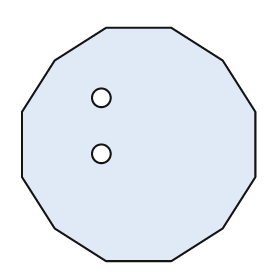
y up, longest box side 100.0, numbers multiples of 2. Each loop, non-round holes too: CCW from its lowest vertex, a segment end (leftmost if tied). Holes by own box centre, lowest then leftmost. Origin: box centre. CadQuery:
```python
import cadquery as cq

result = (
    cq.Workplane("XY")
    .moveTo(-14.0, -50.0)
    .lineTo(14.0, -50.0)
    .lineTo(36.0, -36.0)
    .lineTo(50.0, -14.0)
    .lineTo(50.0, 14.0)
    .lineTo(36.0, 36.0)
    .lineTo(14.0, 50.0)
    .lineTo(-14.0, 50.0)
    .lineTo(-36.0, 36.0)
    .lineTo(-50.0, 14.0)
    .lineTo(-50.0, -14.0)
    .lineTo(-36.0, -36.0)
    .close()
    .moveTo(-16.0, -4.0)
    .circle(4.0)
    .moveTo(-16.0, 20.0)
    .circle(4.0)
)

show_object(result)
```